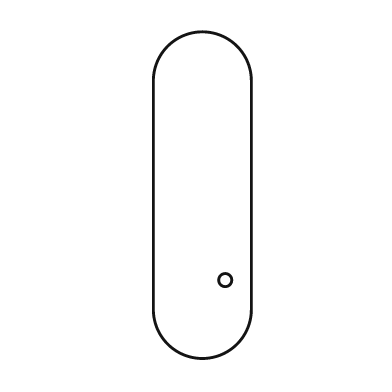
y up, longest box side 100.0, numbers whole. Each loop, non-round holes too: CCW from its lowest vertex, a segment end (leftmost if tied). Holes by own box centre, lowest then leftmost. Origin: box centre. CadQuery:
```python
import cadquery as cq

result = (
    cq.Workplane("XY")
    .moveTo(-15.0, -35.0)
    .threePointArc((0.0, -50.0), (15.0, -35.0))
    .lineTo(15.0, 35.0)
    .threePointArc((0.0, 50.0), (-15.0, 35.0))
    .close()
    .moveTo(7.0, -26.0)
    .circle(2.0)
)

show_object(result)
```